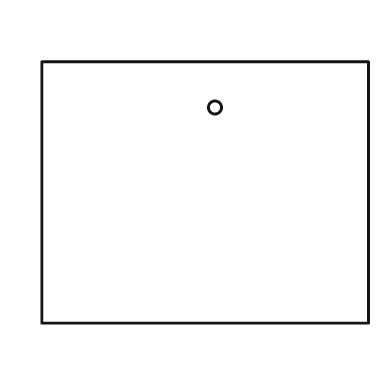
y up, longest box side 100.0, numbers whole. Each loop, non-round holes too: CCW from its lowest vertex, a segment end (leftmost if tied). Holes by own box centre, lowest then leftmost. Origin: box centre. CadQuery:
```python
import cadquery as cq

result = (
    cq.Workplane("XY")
    .moveTo(-50.0, -40.0)
    .lineTo(50.0, -40.0)
    .lineTo(50.0, 40.0)
    .lineTo(-50.0, 40.0)
    .close()
    .moveTo(3.0, 26.0)
    .circle(2.0)
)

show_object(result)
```